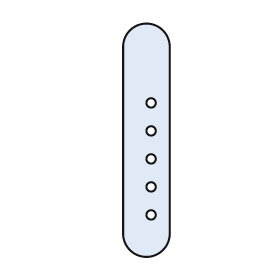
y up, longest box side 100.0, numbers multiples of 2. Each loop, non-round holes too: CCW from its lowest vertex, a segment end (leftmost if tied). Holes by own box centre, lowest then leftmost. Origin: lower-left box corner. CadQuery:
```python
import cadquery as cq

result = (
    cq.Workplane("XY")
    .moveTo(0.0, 10.0)
    .threePointArc((10.0, 0.0), (20.0, 10.0))
    .lineTo(20.0, 90.0)
    .threePointArc((10.0, 100.0), (0.0, 90.0))
    .close()
    .moveTo(12.0, 18.0)
    .circle(2.0)
    .moveTo(12.0, 30.0)
    .circle(2.0)
    .moveTo(12.0, 42.0)
    .circle(2.0)
    .moveTo(12.0, 54.0)
    .circle(2.0)
    .moveTo(12.0, 66.0)
    .circle(2.0)
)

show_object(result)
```